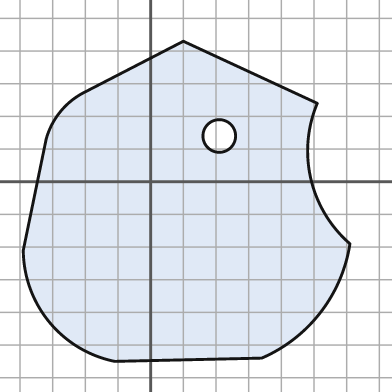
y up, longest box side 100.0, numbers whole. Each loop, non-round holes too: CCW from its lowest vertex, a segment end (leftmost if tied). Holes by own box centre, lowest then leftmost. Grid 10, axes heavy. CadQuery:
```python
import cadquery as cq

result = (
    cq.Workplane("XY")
    .moveTo(-11.0, -55.0)
    .lineTo(34.0, -54.0)
    .threePointArc((52.0, -40.0), (61.0, -19.0))
    .threePointArc((49.0, 1.0), (51.0, 24.0))
    .lineTo(10.0, 43.0)
    .lineTo(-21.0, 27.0)
    .threePointArc((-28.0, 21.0), (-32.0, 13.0))
    .lineTo(-39.0, -21.0)
    .threePointArc((-31.0, -43.0), (-11.0, -55.0))
    .close()
    .moveTo(21.0, 14.0)
    .circle(5.0)
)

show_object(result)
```